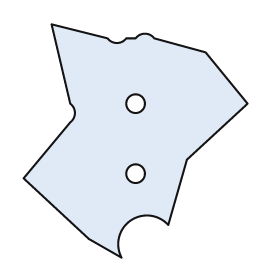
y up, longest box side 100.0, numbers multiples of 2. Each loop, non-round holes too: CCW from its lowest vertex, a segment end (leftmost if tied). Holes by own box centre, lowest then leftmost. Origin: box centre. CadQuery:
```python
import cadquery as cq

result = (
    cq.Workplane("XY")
    .moveTo(-6.0, -50.0)
    .threePointArc((-2.0, -34.0), (14.0, -36.0))
    .lineTo(22.0, -8.0)
    .lineTo(48.0, 16.0)
    .lineTo(30.0, 38.0)
    .lineTo(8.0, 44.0)
    .threePointArc((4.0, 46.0), (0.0, 44.0))
    .lineTo(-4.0, 44.0)
    .threePointArc((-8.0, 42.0), (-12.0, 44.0))
    .lineTo(-36.0, 50.0)
    .lineTo(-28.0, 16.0)
    .threePointArc((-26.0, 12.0), (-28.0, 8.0))
    .lineTo(-48.0, -16.0)
    .lineTo(-20.0, -42.0)
    .close()
    .moveTo(0.0, -14.0)
    .circle(4.0)
    .moveTo(0.0, 16.0)
    .circle(4.0)
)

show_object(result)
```